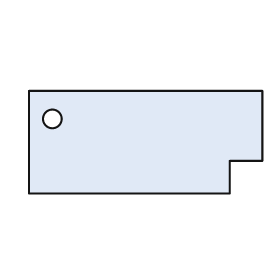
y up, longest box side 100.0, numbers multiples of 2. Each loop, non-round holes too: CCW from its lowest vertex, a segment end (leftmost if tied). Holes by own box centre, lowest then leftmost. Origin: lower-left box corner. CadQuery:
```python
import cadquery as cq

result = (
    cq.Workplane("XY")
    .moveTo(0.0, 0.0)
    .lineTo(86.0, 0.0)
    .lineTo(86.0, 14.0)
    .lineTo(100.0, 14.0)
    .lineTo(100.0, 44.0)
    .lineTo(0.0, 44.0)
    .close()
    .moveTo(10.0, 32.0)
    .circle(4.0)
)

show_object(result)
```